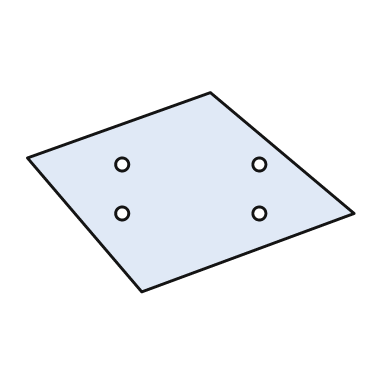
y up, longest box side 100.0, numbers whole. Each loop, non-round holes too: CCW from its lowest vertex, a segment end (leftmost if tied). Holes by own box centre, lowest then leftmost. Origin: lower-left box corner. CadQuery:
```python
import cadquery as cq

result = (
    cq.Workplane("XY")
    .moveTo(35.0, 0.0)
    .lineTo(100.0, 24.0)
    .lineTo(56.0, 61.0)
    .lineTo(0.0, 41.0)
    .close()
    .moveTo(29.0, 24.0)
    .circle(2.0)
    .moveTo(71.0, 24.0)
    .circle(2.0)
    .moveTo(29.0, 39.0)
    .circle(2.0)
    .moveTo(71.0, 39.0)
    .circle(2.0)
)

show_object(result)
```